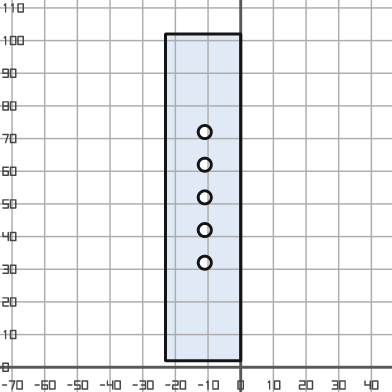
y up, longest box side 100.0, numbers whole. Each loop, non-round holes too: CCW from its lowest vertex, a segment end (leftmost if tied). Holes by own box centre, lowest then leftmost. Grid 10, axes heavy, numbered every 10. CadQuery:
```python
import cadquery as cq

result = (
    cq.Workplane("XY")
    .moveTo(-23.0, 2.0)
    .lineTo(0.0, 2.0)
    .lineTo(0.0, 102.0)
    .lineTo(-23.0, 102.0)
    .close()
    .moveTo(-11.0, 32.0)
    .circle(2.0)
    .moveTo(-11.0, 42.0)
    .circle(2.0)
    .moveTo(-11.0, 52.0)
    .circle(2.0)
    .moveTo(-11.0, 62.0)
    .circle(2.0)
    .moveTo(-11.0, 72.0)
    .circle(2.0)
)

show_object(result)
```